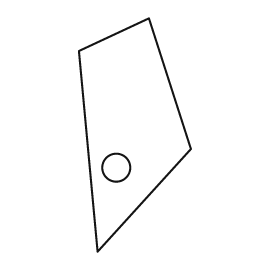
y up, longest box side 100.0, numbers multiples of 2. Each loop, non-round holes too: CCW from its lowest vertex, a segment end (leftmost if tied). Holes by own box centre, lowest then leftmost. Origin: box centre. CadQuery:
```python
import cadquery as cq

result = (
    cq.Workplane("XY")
    .moveTo(-16.0, -50.0)
    .lineTo(24.0, -6.0)
    .lineTo(6.0, 50.0)
    .lineTo(-24.0, 36.0)
    .close()
    .moveTo(-8.0, -14.0)
    .circle(6.0)
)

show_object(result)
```